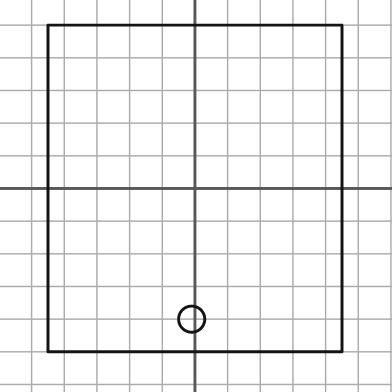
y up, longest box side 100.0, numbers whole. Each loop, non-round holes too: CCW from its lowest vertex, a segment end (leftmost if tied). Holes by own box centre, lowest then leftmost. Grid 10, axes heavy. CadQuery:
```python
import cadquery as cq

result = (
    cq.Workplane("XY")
    .moveTo(-45.0, -50.0)
    .lineTo(45.0, -50.0)
    .lineTo(45.0, 50.0)
    .lineTo(-45.0, 50.0)
    .close()
    .moveTo(-1.0, -40.0)
    .circle(4.0)
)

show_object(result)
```